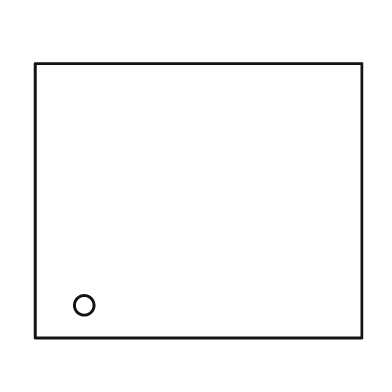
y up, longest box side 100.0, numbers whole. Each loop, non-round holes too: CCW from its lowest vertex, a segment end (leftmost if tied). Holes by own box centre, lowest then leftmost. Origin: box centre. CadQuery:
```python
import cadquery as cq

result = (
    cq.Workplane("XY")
    .moveTo(-50.0, -42.0)
    .lineTo(50.0, -42.0)
    .lineTo(50.0, 42.0)
    .lineTo(-50.0, 42.0)
    .close()
    .moveTo(-35.0, -32.0)
    .circle(3.0)
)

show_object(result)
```